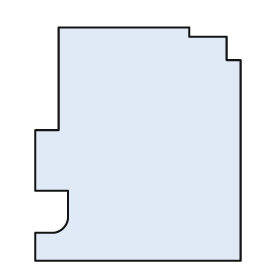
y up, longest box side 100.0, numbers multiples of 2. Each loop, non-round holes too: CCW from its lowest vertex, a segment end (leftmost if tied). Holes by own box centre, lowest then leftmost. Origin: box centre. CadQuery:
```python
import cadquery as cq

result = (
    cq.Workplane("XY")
    .moveTo(-44.0, -50.0)
    .lineTo(44.0, -50.0)
    .lineTo(44.0, 36.0)
    .lineTo(38.0, 36.0)
    .lineTo(38.0, 46.0)
    .lineTo(22.0, 46.0)
    .lineTo(22.0, 50.0)
    .lineTo(-34.0, 50.0)
    .lineTo(-34.0, 6.0)
    .lineTo(-44.0, 6.0)
    .lineTo(-44.0, -20.0)
    .lineTo(-30.0, -20.0)
    .lineTo(-30.0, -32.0)
    .threePointArc((-32.0, -36.0), (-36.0, -38.0))
    .lineTo(-44.0, -38.0)
    .close()
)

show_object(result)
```